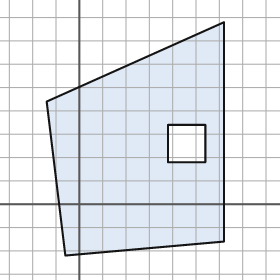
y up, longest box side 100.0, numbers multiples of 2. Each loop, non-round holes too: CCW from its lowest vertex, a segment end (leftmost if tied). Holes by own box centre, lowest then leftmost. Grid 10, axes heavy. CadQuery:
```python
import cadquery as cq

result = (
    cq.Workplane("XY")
    .moveTo(-6.0, -22.0)
    .lineTo(62.0, -16.0)
    .lineTo(62.0, 78.0)
    .lineTo(-14.0, 44.0)
    .close()
    .moveTo(38.0, 18.0)
    .lineTo(54.0, 18.0)
    .lineTo(54.0, 34.0)
    .lineTo(38.0, 34.0)
    .close()
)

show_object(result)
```